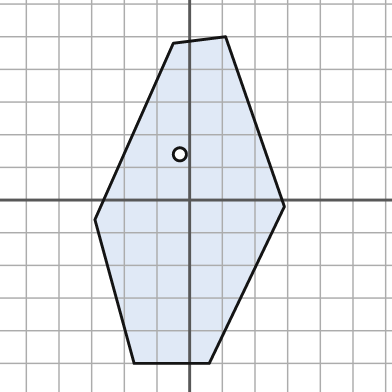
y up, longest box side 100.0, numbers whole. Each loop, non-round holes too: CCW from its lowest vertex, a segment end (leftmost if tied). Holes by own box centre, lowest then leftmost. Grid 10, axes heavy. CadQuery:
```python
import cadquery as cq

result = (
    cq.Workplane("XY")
    .moveTo(-17.0, -50.0)
    .lineTo(6.0, -50.0)
    .lineTo(29.0, -2.0)
    .lineTo(11.0, 50.0)
    .lineTo(-5.0, 48.0)
    .lineTo(-29.0, -6.0)
    .close()
    .moveTo(-3.0, 14.0)
    .circle(2.0)
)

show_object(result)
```